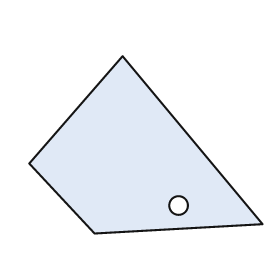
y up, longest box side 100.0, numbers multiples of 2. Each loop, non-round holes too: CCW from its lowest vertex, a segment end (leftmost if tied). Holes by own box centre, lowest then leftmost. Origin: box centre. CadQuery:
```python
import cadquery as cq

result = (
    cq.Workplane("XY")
    .moveTo(-22.0, -38.0)
    .lineTo(50.0, -34.0)
    .lineTo(-10.0, 38.0)
    .lineTo(-50.0, -8.0)
    .close()
    .moveTo(14.0, -26.0)
    .circle(4.0)
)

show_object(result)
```